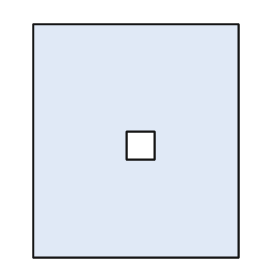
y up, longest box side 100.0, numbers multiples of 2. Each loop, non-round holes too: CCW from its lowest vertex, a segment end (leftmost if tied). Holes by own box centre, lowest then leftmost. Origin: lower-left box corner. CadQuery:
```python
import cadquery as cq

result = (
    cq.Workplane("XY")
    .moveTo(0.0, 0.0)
    .lineTo(88.0, 0.0)
    .lineTo(88.0, 100.0)
    .lineTo(0.0, 100.0)
    .close()
    .moveTo(40.0, 42.0)
    .lineTo(52.0, 42.0)
    .lineTo(52.0, 54.0)
    .lineTo(40.0, 54.0)
    .close()
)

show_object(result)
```